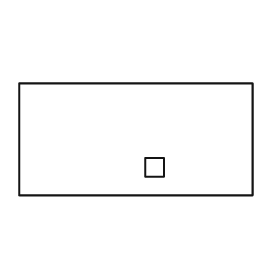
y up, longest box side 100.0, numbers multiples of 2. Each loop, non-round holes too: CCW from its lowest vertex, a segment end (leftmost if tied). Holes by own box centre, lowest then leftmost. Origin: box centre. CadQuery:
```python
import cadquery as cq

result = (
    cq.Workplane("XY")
    .moveTo(-50.0, -24.0)
    .lineTo(50.0, -24.0)
    .lineTo(50.0, 24.0)
    .lineTo(-50.0, 24.0)
    .close()
    .moveTo(4.0, -16.0)
    .lineTo(12.0, -16.0)
    .lineTo(12.0, -8.0)
    .lineTo(4.0, -8.0)
    .close()
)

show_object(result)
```